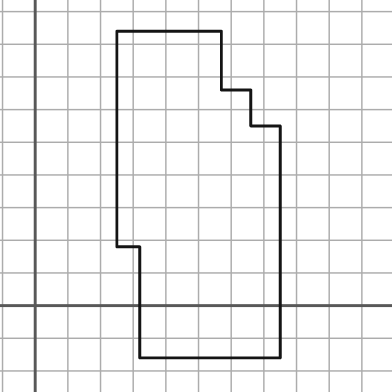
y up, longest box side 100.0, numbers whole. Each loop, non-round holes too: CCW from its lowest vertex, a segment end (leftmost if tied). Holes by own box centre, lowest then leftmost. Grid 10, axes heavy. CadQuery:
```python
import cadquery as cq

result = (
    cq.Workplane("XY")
    .moveTo(32.0, -16.0)
    .lineTo(75.0, -16.0)
    .lineTo(75.0, 55.0)
    .lineTo(66.0, 55.0)
    .lineTo(66.0, 66.0)
    .lineTo(57.0, 66.0)
    .lineTo(57.0, 84.0)
    .lineTo(25.0, 84.0)
    .lineTo(25.0, 18.0)
    .lineTo(32.0, 18.0)
    .close()
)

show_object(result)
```